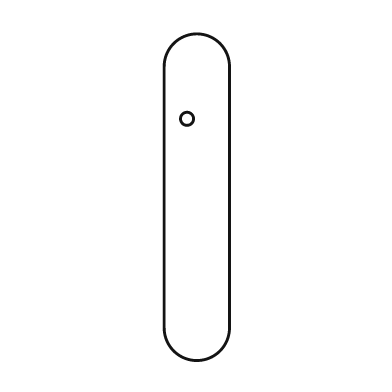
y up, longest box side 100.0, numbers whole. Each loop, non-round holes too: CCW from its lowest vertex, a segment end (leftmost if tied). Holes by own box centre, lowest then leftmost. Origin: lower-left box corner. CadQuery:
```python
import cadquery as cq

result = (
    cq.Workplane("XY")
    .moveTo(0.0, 10.0)
    .threePointArc((10.0, 0.0), (20.0, 10.0))
    .lineTo(20.0, 90.0)
    .threePointArc((10.0, 100.0), (0.0, 90.0))
    .close()
    .moveTo(7.0, 74.0)
    .circle(2.0)
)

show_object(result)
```